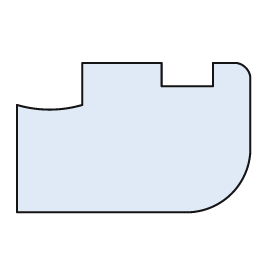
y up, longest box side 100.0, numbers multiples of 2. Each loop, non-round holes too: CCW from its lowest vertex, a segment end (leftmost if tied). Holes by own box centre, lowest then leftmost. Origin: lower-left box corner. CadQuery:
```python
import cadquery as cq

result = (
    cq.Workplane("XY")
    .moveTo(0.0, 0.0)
    .lineTo(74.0, 0.0)
    .threePointArc((92.0, 8.0), (100.0, 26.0))
    .lineTo(100.0, 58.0)
    .threePointArc((98.0, 62.0), (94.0, 64.0))
    .lineTo(84.0, 64.0)
    .lineTo(84.0, 54.0)
    .lineTo(62.0, 54.0)
    .lineTo(62.0, 64.0)
    .lineTo(28.0, 64.0)
    .lineTo(28.0, 46.0)
    .threePointArc((14.0, 44.0), (0.0, 46.0))
    .close()
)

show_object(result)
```